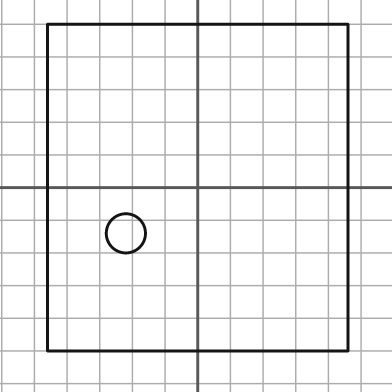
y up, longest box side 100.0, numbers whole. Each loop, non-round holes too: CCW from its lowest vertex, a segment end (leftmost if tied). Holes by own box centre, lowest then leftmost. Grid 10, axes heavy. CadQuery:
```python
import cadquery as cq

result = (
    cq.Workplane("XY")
    .moveTo(-46.0, -50.0)
    .lineTo(46.0, -50.0)
    .lineTo(46.0, 50.0)
    .lineTo(-46.0, 50.0)
    .close()
    .moveTo(-22.0, -14.0)
    .circle(6.0)
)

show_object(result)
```